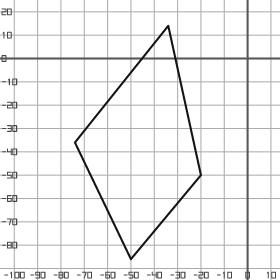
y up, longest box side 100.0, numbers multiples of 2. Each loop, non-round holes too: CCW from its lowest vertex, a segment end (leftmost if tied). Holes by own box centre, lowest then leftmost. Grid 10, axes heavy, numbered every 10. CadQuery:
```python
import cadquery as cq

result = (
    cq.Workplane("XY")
    .moveTo(-50.0, -86.0)
    .lineTo(-20.0, -50.0)
    .lineTo(-34.0, 14.0)
    .lineTo(-74.0, -36.0)
    .close()
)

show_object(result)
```